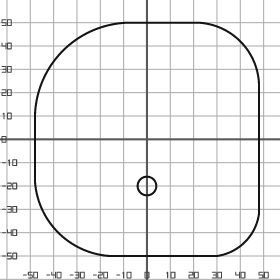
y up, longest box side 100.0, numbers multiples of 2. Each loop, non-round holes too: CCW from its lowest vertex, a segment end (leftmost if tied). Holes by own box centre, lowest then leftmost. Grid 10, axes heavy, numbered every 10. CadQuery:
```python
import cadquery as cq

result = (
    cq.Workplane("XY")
    .moveTo(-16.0, -50.0)
    .lineTo(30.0, -50.0)
    .threePointArc((42.0, -44.0), (48.0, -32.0))
    .lineTo(48.0, 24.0)
    .threePointArc((40.0, 42.0), (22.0, 50.0))
    .lineTo(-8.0, 50.0)
    .threePointArc((-36.0, 38.0), (-48.0, 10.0))
    .lineTo(-48.0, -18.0)
    .threePointArc((-38.0, -40.0), (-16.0, -50.0))
    .close()
    .moveTo(0.0, -20.0)
    .circle(4.0)
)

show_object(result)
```